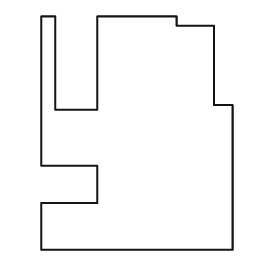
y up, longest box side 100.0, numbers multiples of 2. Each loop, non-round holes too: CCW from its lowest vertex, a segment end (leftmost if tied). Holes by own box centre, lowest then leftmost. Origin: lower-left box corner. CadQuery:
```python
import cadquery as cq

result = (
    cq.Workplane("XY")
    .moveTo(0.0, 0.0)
    .lineTo(82.0, 0.0)
    .lineTo(82.0, 62.0)
    .lineTo(74.0, 62.0)
    .lineTo(74.0, 96.0)
    .lineTo(58.0, 96.0)
    .lineTo(58.0, 100.0)
    .lineTo(24.0, 100.0)
    .lineTo(24.0, 60.0)
    .lineTo(6.0, 60.0)
    .lineTo(6.0, 100.0)
    .lineTo(0.0, 100.0)
    .lineTo(0.0, 36.0)
    .lineTo(24.0, 36.0)
    .lineTo(24.0, 20.0)
    .lineTo(0.0, 20.0)
    .close()
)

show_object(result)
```